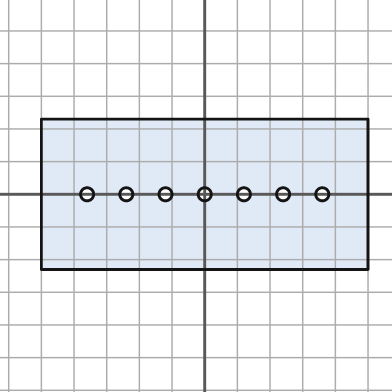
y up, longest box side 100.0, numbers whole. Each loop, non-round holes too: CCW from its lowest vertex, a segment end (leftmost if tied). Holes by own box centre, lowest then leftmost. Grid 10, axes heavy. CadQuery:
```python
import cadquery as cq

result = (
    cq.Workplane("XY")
    .moveTo(-50.0, -23.0)
    .lineTo(50.0, -23.0)
    .lineTo(50.0, 23.0)
    .lineTo(-50.0, 23.0)
    .close()
    .moveTo(-36.0, 0.0)
    .circle(2.0)
    .moveTo(-24.0, 0.0)
    .circle(2.0)
    .moveTo(-12.0, 0.0)
    .circle(2.0)
    .moveTo(0.0, 0.0)
    .circle(2.0)
    .moveTo(12.0, 0.0)
    .circle(2.0)
    .moveTo(24.0, 0.0)
    .circle(2.0)
    .moveTo(36.0, 0.0)
    .circle(2.0)
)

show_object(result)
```